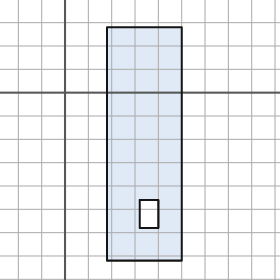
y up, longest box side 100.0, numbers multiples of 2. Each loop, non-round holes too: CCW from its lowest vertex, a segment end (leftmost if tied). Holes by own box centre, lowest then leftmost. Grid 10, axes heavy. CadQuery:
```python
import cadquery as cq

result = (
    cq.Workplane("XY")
    .moveTo(18.0, -72.0)
    .lineTo(50.0, -72.0)
    .lineTo(50.0, 28.0)
    .lineTo(18.0, 28.0)
    .close()
    .moveTo(32.0, -58.0)
    .lineTo(40.0, -58.0)
    .lineTo(40.0, -46.0)
    .lineTo(32.0, -46.0)
    .close()
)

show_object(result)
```